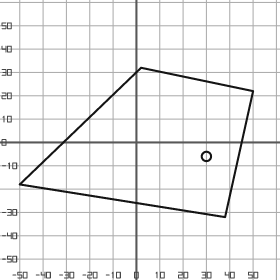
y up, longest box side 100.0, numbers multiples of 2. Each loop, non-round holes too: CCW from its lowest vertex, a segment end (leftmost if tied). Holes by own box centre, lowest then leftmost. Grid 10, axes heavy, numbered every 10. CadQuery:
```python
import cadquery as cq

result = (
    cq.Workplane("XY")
    .moveTo(38.0, -32.0)
    .lineTo(50.0, 22.0)
    .lineTo(2.0, 32.0)
    .lineTo(-50.0, -18.0)
    .close()
    .moveTo(30.0, -6.0)
    .circle(2.0)
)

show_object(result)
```